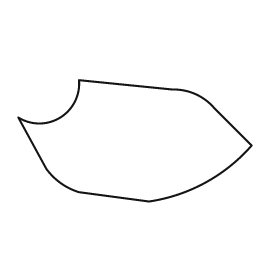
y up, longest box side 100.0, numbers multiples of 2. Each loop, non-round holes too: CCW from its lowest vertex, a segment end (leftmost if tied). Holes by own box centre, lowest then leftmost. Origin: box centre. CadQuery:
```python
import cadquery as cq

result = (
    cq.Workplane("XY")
    .moveTo(6.0, -26.0)
    .threePointArc((30.0, -18.0), (50.0, -2.0))
    .lineTo(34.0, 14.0)
    .threePointArc((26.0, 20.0), (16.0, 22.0))
    .lineTo(-24.0, 26.0)
    .threePointArc((-32.0, 10.0), (-50.0, 10.0))
    .lineTo(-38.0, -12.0)
    .threePointArc((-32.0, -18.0), (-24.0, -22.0))
    .close()
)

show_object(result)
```